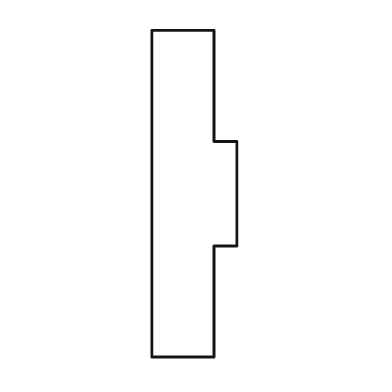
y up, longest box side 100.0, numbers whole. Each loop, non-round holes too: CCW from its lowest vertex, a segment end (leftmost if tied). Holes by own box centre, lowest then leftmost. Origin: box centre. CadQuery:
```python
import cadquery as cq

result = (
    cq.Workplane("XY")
    .moveTo(-13.0, -50.0)
    .lineTo(6.0, -50.0)
    .lineTo(6.0, -16.0)
    .lineTo(13.0, -16.0)
    .lineTo(13.0, 16.0)
    .lineTo(6.0, 16.0)
    .lineTo(6.0, 50.0)
    .lineTo(-13.0, 50.0)
    .close()
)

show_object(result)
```